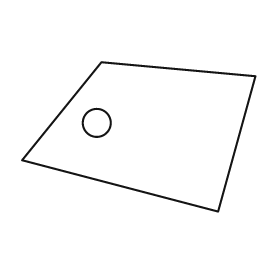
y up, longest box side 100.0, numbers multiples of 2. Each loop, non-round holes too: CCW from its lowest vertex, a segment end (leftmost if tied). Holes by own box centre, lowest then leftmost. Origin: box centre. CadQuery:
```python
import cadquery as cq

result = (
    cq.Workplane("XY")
    .moveTo(34.0, -32.0)
    .lineTo(50.0, 26.0)
    .lineTo(-16.0, 32.0)
    .lineTo(-50.0, -10.0)
    .close()
    .moveTo(-18.0, 6.0)
    .circle(6.0)
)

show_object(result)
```